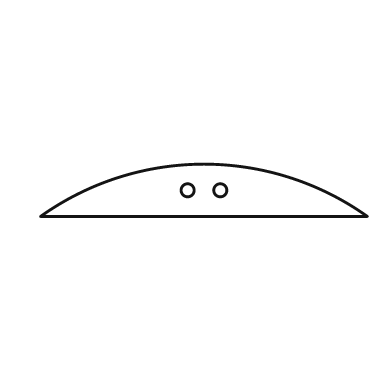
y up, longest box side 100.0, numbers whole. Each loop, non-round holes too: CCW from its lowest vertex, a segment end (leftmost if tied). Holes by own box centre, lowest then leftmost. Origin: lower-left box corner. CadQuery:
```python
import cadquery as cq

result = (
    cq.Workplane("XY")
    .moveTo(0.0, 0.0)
    .lineTo(100.0, 0.0)
    .threePointArc((50.0, 16.0), (0.0, 0.0))
    .close()
    .moveTo(45.0, 8.0)
    .circle(2.0)
    .moveTo(55.0, 8.0)
    .circle(2.0)
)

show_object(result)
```